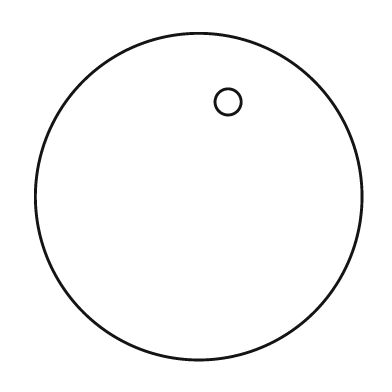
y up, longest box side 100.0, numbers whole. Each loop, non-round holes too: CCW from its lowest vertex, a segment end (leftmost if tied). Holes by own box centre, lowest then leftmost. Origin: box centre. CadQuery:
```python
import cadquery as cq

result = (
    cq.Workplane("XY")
    .moveTo(0.0, 0.0)
    .circle(50.0)
    .moveTo(9.0, 29.0)
    .circle(4.0)
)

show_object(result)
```